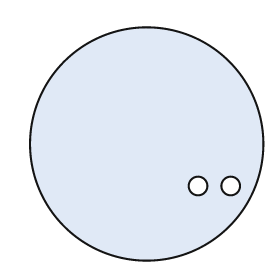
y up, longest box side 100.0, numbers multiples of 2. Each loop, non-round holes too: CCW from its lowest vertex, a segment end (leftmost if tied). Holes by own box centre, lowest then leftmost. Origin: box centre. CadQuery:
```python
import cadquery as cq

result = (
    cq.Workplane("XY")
    .moveTo(0.0, 0.0)
    .circle(50.0)
    .moveTo(22.0, -18.0)
    .circle(4.0)
    .moveTo(36.0, -18.0)
    .circle(4.0)
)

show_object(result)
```